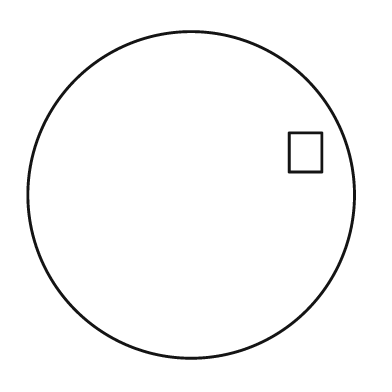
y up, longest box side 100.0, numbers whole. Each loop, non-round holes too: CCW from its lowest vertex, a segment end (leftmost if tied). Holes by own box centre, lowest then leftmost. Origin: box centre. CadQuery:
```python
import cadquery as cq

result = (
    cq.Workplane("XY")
    .moveTo(0.0, 0.0)
    .circle(50.0)
    .moveTo(30.0, 7.0)
    .lineTo(40.0, 7.0)
    .lineTo(40.0, 19.0)
    .lineTo(30.0, 19.0)
    .close()
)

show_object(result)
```